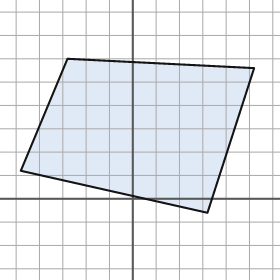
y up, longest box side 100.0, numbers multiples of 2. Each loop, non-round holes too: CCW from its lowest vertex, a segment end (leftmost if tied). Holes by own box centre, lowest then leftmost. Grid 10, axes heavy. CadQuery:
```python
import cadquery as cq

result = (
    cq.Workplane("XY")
    .moveTo(32.0, -6.0)
    .lineTo(52.0, 56.0)
    .lineTo(-28.0, 60.0)
    .lineTo(-48.0, 12.0)
    .close()
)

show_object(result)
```